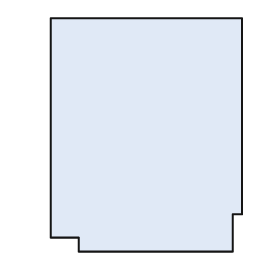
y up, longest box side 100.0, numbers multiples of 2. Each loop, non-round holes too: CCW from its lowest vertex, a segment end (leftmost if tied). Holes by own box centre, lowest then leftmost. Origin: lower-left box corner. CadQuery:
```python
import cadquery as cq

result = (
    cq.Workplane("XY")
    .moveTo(12.0, 0.0)
    .lineTo(78.0, 0.0)
    .lineTo(78.0, 16.0)
    .lineTo(82.0, 16.0)
    .lineTo(82.0, 100.0)
    .lineTo(0.0, 100.0)
    .lineTo(0.0, 6.0)
    .lineTo(12.0, 6.0)
    .close()
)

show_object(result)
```